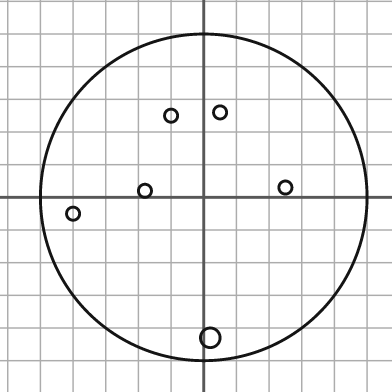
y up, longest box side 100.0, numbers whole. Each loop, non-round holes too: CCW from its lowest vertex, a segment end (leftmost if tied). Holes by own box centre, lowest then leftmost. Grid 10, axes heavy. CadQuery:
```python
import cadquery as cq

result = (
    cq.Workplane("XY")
    .moveTo(0.0, 0.0)
    .circle(50.0)
    .moveTo(2.0, -43.0)
    .circle(3.0)
    .moveTo(-40.0, -5.0)
    .circle(2.0)
    .moveTo(-18.0, 2.0)
    .circle(2.0)
    .moveTo(25.0, 3.0)
    .circle(2.0)
    .moveTo(-10.0, 25.0)
    .circle(2.0)
    .moveTo(5.0, 26.0)
    .circle(2.0)
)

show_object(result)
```